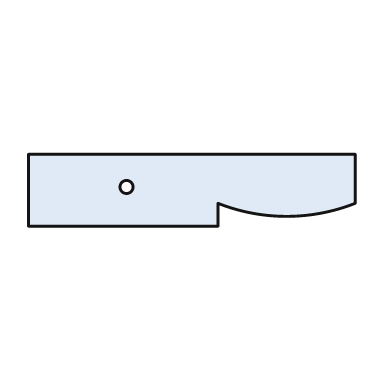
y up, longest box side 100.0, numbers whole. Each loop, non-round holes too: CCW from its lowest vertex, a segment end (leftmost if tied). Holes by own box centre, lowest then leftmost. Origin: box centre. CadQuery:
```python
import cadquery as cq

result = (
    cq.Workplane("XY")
    .moveTo(-50.0, -11.0)
    .lineTo(8.0, -11.0)
    .lineTo(8.0, -4.0)
    .threePointArc((29.0, -8.0), (50.0, -4.0))
    .lineTo(50.0, 11.0)
    .lineTo(-50.0, 11.0)
    .close()
    .moveTo(-20.0, 1.0)
    .circle(2.0)
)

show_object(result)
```